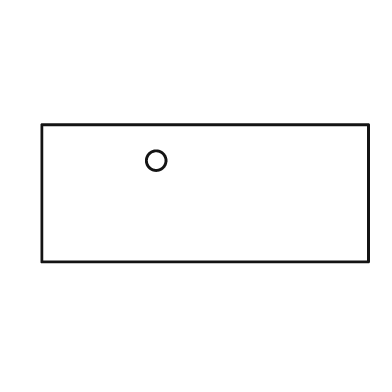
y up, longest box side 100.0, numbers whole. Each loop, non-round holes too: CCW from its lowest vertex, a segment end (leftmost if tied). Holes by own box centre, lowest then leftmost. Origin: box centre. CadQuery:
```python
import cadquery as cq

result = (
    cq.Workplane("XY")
    .moveTo(-50.0, -21.0)
    .lineTo(50.0, -21.0)
    .lineTo(50.0, 21.0)
    .lineTo(-50.0, 21.0)
    .close()
    .moveTo(-15.0, 10.0)
    .circle(3.0)
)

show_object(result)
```